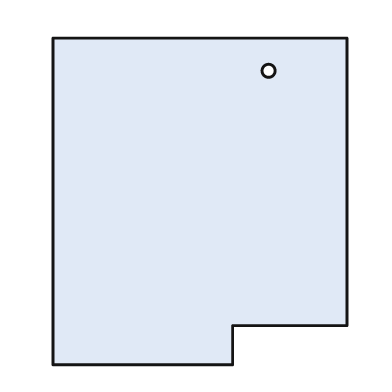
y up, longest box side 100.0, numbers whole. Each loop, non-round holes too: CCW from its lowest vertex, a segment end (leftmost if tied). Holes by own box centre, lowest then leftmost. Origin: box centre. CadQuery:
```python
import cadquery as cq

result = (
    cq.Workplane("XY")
    .moveTo(-45.0, -50.0)
    .lineTo(10.0, -50.0)
    .lineTo(10.0, -38.0)
    .lineTo(45.0, -38.0)
    .lineTo(45.0, 50.0)
    .lineTo(-45.0, 50.0)
    .close()
    .moveTo(21.0, 40.0)
    .circle(2.0)
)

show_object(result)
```